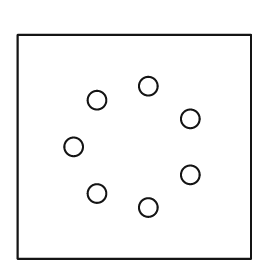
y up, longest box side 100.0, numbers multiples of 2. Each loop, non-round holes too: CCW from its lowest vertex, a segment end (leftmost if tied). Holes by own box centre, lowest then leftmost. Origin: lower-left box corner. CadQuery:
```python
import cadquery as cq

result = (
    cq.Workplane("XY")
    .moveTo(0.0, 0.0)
    .lineTo(100.0, 0.0)
    .lineTo(100.0, 96.0)
    .lineTo(0.0, 96.0)
    .close()
    .moveTo(56.0, 22.0)
    .circle(4.0)
    .moveTo(34.0, 28.0)
    .circle(4.0)
    .moveTo(74.0, 36.0)
    .circle(4.0)
    .moveTo(24.0, 48.0)
    .circle(4.0)
    .moveTo(74.0, 60.0)
    .circle(4.0)
    .moveTo(34.0, 68.0)
    .circle(4.0)
    .moveTo(56.0, 74.0)
    .circle(4.0)
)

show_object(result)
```